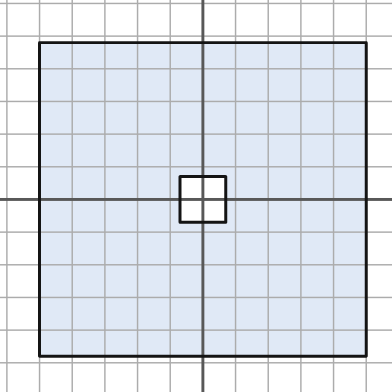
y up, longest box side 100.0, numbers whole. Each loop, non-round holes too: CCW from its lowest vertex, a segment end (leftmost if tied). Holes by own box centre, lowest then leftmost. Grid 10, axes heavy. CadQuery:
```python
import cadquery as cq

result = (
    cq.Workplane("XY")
    .moveTo(-50.0, -48.0)
    .lineTo(50.0, -48.0)
    .lineTo(50.0, 48.0)
    .lineTo(-50.0, 48.0)
    .close()
    .moveTo(-7.0, -7.0)
    .lineTo(7.0, -7.0)
    .lineTo(7.0, 7.0)
    .lineTo(-7.0, 7.0)
    .close()
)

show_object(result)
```